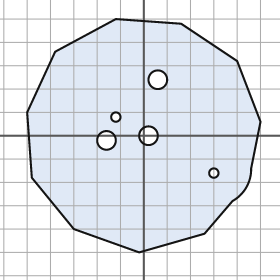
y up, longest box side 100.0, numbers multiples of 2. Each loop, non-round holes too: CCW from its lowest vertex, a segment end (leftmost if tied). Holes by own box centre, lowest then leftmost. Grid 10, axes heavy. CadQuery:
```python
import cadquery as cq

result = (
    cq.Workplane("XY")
    .moveTo(-2.0, -50.0)
    .lineTo(26.0, -42.0)
    .lineTo(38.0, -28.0)
    .threePointArc((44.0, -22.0), (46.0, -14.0))
    .lineTo(50.0, 6.0)
    .lineTo(40.0, 32.0)
    .lineTo(16.0, 48.0)
    .lineTo(-12.0, 50.0)
    .lineTo(-38.0, 36.0)
    .lineTo(-50.0, 10.0)
    .lineTo(-48.0, -18.0)
    .lineTo(-30.0, -40.0)
    .close()
    .moveTo(30.0, -16.0)
    .circle(2.0)
    .moveTo(-16.0, -2.0)
    .circle(4.0)
    .moveTo(2.0, 0.0)
    .circle(4.0)
    .moveTo(-12.0, 8.0)
    .circle(2.0)
    .moveTo(6.0, 24.0)
    .circle(4.0)
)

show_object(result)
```